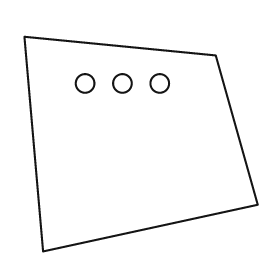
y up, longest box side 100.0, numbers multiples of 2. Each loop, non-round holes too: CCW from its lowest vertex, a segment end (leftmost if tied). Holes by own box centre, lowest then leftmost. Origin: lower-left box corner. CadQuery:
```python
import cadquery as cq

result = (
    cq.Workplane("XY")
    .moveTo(8.0, 0.0)
    .lineTo(100.0, 20.0)
    .lineTo(82.0, 84.0)
    .lineTo(0.0, 92.0)
    .close()
    .moveTo(26.0, 72.0)
    .circle(4.0)
    .moveTo(42.0, 72.0)
    .circle(4.0)
    .moveTo(58.0, 72.0)
    .circle(4.0)
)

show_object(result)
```